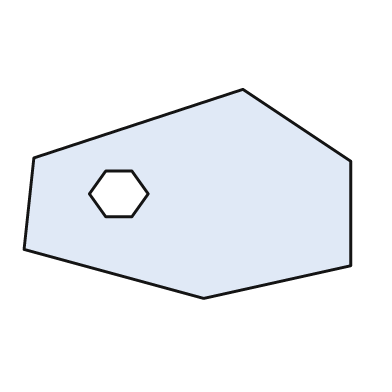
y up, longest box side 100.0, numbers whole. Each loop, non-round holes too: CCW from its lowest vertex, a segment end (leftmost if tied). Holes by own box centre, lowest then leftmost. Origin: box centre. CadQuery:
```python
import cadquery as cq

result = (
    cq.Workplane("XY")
    .moveTo(5.0, -32.0)
    .lineTo(50.0, -22.0)
    .lineTo(50.0, 10.0)
    .lineTo(17.0, 32.0)
    .lineTo(-47.0, 11.0)
    .lineTo(-50.0, -17.0)
    .close()
    .moveTo(-25.0, -7.0)
    .lineTo(-17.0, -7.0)
    .lineTo(-12.0, 0.0)
    .lineTo(-17.0, 7.0)
    .lineTo(-25.0, 7.0)
    .lineTo(-30.0, 0.0)
    .close()
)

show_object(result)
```